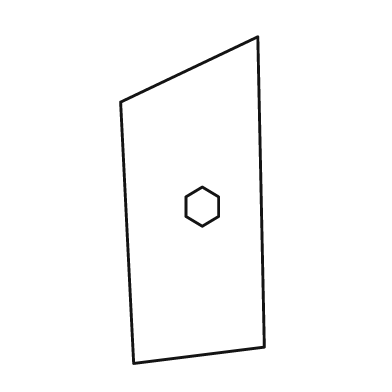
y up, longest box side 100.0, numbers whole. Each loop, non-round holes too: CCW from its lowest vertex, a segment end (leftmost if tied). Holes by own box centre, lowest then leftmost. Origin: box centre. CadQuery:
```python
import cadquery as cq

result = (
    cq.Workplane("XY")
    .moveTo(-18.0, -50.0)
    .lineTo(22.0, -45.0)
    .lineTo(20.0, 50.0)
    .lineTo(-22.0, 30.0)
    .close()
    .moveTo(3.0, -8.0)
    .lineTo(8.0, -5.0)
    .lineTo(8.0, 1.0)
    .lineTo(3.0, 4.0)
    .lineTo(-2.0, 1.0)
    .lineTo(-2.0, -5.0)
    .close()
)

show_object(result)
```